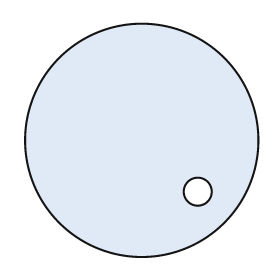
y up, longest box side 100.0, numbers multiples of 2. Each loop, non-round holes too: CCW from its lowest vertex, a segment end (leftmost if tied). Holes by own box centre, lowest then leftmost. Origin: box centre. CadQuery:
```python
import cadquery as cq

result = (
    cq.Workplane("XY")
    .moveTo(0.0, 0.0)
    .circle(50.0)
    .moveTo(24.0, -22.0)
    .circle(6.0)
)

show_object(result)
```